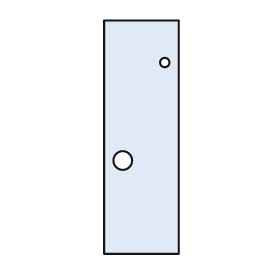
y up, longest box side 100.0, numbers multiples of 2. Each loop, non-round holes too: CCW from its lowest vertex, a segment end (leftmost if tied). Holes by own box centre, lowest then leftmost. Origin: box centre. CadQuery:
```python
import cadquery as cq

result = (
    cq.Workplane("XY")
    .moveTo(-16.0, -50.0)
    .lineTo(16.0, -50.0)
    .lineTo(16.0, 50.0)
    .lineTo(-16.0, 50.0)
    .close()
    .moveTo(-8.0, -10.0)
    .circle(4.0)
    .moveTo(10.0, 32.0)
    .circle(2.0)
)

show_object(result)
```